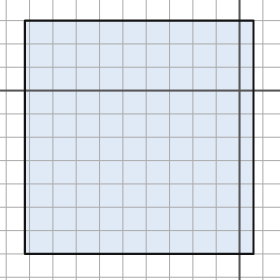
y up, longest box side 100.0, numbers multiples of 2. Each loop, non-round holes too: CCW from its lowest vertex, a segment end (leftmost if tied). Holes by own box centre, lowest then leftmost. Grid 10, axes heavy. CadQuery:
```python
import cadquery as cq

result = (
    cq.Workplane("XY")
    .moveTo(-92.0, -70.0)
    .lineTo(6.0, -70.0)
    .lineTo(6.0, 30.0)
    .lineTo(-92.0, 30.0)
    .close()
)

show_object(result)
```